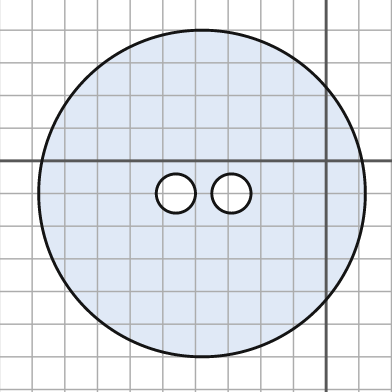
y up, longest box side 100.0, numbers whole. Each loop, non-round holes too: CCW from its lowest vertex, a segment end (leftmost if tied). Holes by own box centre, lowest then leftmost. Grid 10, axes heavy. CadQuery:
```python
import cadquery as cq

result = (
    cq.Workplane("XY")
    .moveTo(-38.0, -10.0)
    .circle(50.0)
    .moveTo(-46.0, -10.0)
    .circle(6.0)
    .moveTo(-29.0, -10.0)
    .circle(6.0)
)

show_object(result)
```